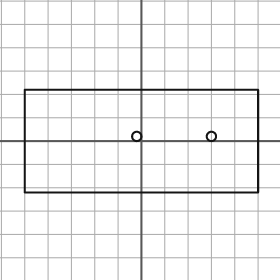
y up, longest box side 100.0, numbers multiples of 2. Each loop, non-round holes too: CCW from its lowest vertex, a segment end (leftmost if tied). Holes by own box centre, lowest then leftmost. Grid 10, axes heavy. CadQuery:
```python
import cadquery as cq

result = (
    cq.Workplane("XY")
    .moveTo(-50.0, -22.0)
    .lineTo(50.0, -22.0)
    .lineTo(50.0, 22.0)
    .lineTo(-50.0, 22.0)
    .close()
    .moveTo(-2.0, 2.0)
    .circle(2.0)
    .moveTo(30.0, 2.0)
    .circle(2.0)
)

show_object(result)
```